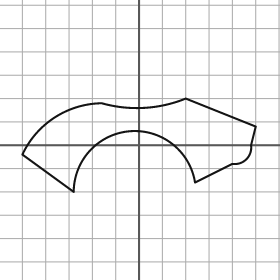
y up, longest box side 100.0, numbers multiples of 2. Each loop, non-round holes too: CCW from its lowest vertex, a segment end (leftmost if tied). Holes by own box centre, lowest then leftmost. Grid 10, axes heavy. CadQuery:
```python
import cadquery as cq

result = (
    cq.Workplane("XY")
    .moveTo(-28.0, -20.0)
    .threePointArc((-4.0, 6.0), (24.0, -16.0))
    .lineTo(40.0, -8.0)
    .threePointArc((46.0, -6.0), (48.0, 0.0))
    .lineTo(50.0, 8.0)
    .lineTo(20.0, 20.0)
    .threePointArc((2.0, 16.0), (-16.0, 18.0))
    .threePointArc((-36.0, 12.0), (-50.0, -4.0))
    .close()
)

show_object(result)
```